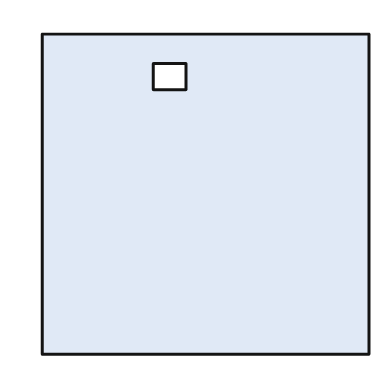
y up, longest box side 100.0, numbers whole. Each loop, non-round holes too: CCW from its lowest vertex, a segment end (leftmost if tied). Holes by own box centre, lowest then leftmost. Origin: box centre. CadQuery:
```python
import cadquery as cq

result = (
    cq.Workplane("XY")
    .moveTo(-50.0, -49.0)
    .lineTo(50.0, -49.0)
    .lineTo(50.0, 49.0)
    .lineTo(-50.0, 49.0)
    .close()
    .moveTo(-16.0, 32.0)
    .lineTo(-6.0, 32.0)
    .lineTo(-6.0, 40.0)
    .lineTo(-16.0, 40.0)
    .close()
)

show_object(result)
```